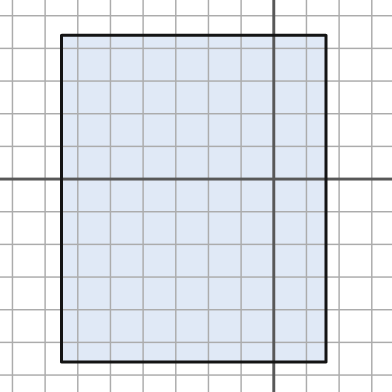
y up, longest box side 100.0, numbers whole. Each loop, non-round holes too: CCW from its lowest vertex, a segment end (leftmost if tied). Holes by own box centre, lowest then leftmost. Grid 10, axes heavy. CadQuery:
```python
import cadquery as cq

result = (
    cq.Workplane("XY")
    .moveTo(-65.0, -56.0)
    .lineTo(16.0, -56.0)
    .lineTo(16.0, 44.0)
    .lineTo(-65.0, 44.0)
    .close()
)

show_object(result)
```